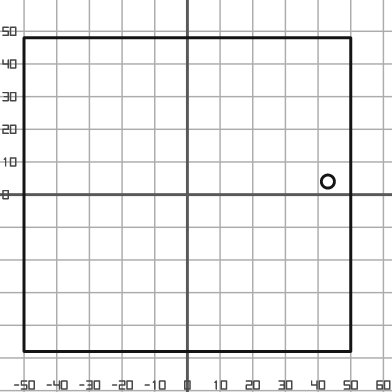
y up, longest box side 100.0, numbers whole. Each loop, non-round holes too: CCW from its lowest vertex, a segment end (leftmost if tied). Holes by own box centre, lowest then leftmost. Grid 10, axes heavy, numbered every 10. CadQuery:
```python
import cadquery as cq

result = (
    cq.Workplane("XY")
    .moveTo(-50.0, -48.0)
    .lineTo(50.0, -48.0)
    .lineTo(50.0, 48.0)
    .lineTo(-50.0, 48.0)
    .close()
    .moveTo(43.0, 4.0)
    .circle(2.0)
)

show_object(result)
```